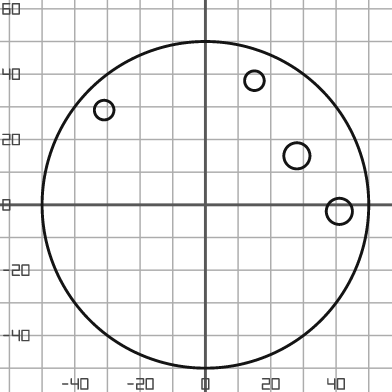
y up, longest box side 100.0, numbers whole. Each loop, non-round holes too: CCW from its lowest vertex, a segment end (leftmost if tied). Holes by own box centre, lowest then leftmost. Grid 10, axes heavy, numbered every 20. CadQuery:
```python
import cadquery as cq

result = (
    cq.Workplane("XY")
    .moveTo(0.0, 0.0)
    .circle(50.0)
    .moveTo(41.0, -2.0)
    .circle(4.0)
    .moveTo(28.0, 15.0)
    .circle(4.0)
    .moveTo(-31.0, 29.0)
    .circle(3.0)
    .moveTo(15.0, 38.0)
    .circle(3.0)
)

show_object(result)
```